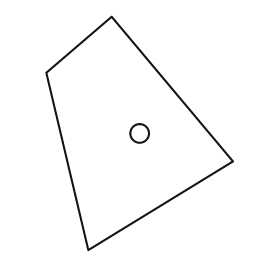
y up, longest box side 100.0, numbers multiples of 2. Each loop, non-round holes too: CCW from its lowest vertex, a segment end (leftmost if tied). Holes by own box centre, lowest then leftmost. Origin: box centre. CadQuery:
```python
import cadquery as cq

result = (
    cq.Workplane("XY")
    .moveTo(-22.0, -50.0)
    .lineTo(40.0, -12.0)
    .lineTo(-12.0, 50.0)
    .lineTo(-40.0, 26.0)
    .close()
    .moveTo(0.0, 0.0)
    .circle(4.0)
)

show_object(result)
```